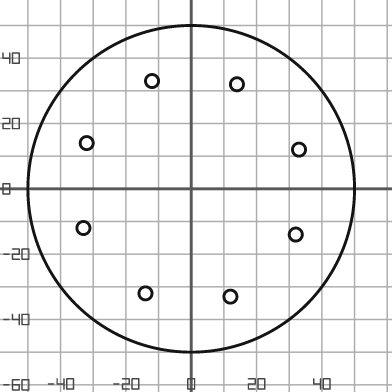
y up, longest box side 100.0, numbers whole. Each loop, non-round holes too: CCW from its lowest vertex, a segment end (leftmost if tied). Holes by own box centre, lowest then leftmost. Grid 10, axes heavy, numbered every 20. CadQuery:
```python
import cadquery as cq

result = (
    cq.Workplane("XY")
    .moveTo(0.0, 0.0)
    .circle(50.0)
    .moveTo(12.0, -33.0)
    .circle(2.0)
    .moveTo(-14.0, -32.0)
    .circle(2.0)
    .moveTo(32.0, -14.0)
    .circle(2.0)
    .moveTo(-33.0, -12.0)
    .circle(2.0)
    .moveTo(33.0, 12.0)
    .circle(2.0)
    .moveTo(-32.0, 14.0)
    .circle(2.0)
    .moveTo(14.0, 32.0)
    .circle(2.0)
    .moveTo(-12.0, 33.0)
    .circle(2.0)
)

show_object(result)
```